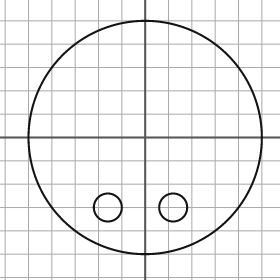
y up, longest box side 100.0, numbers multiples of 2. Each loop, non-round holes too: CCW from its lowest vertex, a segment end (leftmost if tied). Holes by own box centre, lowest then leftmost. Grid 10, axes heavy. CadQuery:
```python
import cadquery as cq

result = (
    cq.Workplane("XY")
    .moveTo(0.0, 0.0)
    .circle(50.0)
    .moveTo(-16.0, -30.0)
    .circle(6.0)
    .moveTo(12.0, -30.0)
    .circle(6.0)
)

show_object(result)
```